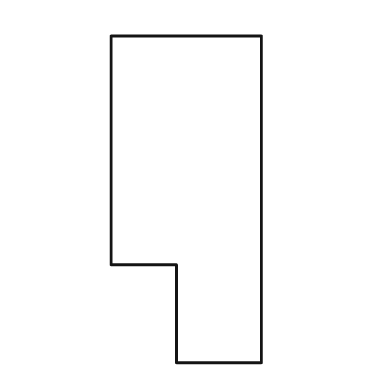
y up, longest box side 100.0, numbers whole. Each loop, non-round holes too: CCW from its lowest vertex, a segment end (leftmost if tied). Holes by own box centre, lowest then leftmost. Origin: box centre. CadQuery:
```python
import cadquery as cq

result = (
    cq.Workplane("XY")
    .moveTo(-3.0, -50.0)
    .lineTo(23.0, -50.0)
    .lineTo(23.0, 50.0)
    .lineTo(-23.0, 50.0)
    .lineTo(-23.0, -20.0)
    .lineTo(-3.0, -20.0)
    .close()
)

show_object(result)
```